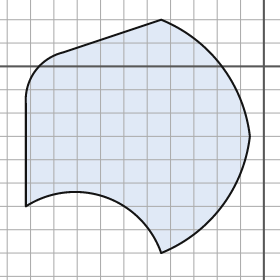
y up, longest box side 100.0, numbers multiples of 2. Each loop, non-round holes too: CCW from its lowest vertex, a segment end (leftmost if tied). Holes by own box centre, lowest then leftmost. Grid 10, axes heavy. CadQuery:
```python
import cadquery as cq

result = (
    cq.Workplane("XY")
    .moveTo(-44.0, -80.0)
    .threePointArc((-18.0, -60.0), (-6.0, -30.0))
    .threePointArc((-18.0, 0.0), (-44.0, 20.0))
    .lineTo(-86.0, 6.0)
    .threePointArc((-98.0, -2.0), (-102.0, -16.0))
    .lineTo(-102.0, -60.0)
    .threePointArc((-68.0, -56.0), (-44.0, -80.0))
    .close()
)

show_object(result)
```